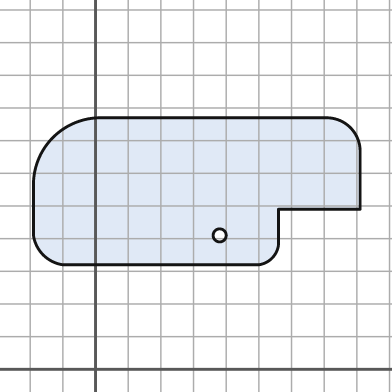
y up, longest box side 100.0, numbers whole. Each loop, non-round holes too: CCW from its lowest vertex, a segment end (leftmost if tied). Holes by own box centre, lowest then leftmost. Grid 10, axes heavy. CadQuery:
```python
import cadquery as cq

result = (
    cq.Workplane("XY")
    .moveTo(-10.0, 32.0)
    .lineTo(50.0, 32.0)
    .threePointArc((54.0, 34.0), (56.0, 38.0))
    .lineTo(56.0, 49.0)
    .lineTo(81.0, 49.0)
    .lineTo(81.0, 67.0)
    .threePointArc((78.0, 74.0), (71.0, 77.0))
    .lineTo(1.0, 77.0)
    .threePointArc((-13.0, 71.0), (-19.0, 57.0))
    .lineTo(-19.0, 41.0)
    .threePointArc((-16.0, 35.0), (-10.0, 32.0))
    .close()
    .moveTo(38.0, 41.0)
    .circle(2.0)
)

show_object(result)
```